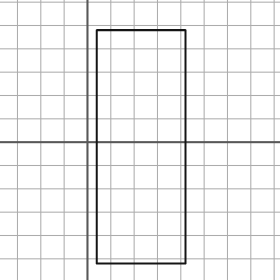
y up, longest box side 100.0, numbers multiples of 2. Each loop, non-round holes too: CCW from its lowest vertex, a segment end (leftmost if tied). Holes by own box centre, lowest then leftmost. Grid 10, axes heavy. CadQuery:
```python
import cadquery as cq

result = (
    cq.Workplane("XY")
    .moveTo(4.0, -52.0)
    .lineTo(42.0, -52.0)
    .lineTo(42.0, 48.0)
    .lineTo(4.0, 48.0)
    .close()
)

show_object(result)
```